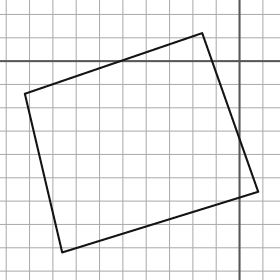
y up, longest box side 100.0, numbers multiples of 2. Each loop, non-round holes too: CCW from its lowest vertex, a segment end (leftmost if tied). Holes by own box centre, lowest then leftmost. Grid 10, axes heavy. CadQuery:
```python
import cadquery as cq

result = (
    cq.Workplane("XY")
    .moveTo(-76.0, -82.0)
    .lineTo(8.0, -56.0)
    .lineTo(-16.0, 12.0)
    .lineTo(-92.0, -14.0)
    .close()
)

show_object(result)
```